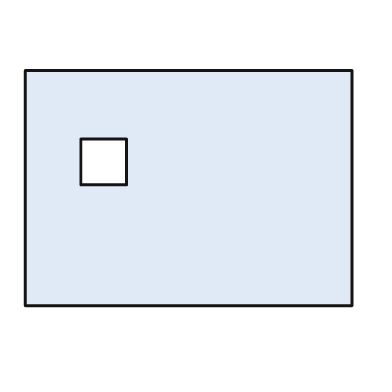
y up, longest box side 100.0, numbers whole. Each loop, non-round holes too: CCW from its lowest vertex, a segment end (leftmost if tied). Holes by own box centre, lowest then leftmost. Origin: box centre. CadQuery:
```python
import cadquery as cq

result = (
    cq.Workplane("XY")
    .moveTo(-50.0, -36.0)
    .lineTo(50.0, -36.0)
    .lineTo(50.0, 36.0)
    .lineTo(-50.0, 36.0)
    .close()
    .moveTo(-33.0, 1.0)
    .lineTo(-19.0, 1.0)
    .lineTo(-19.0, 15.0)
    .lineTo(-33.0, 15.0)
    .close()
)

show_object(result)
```